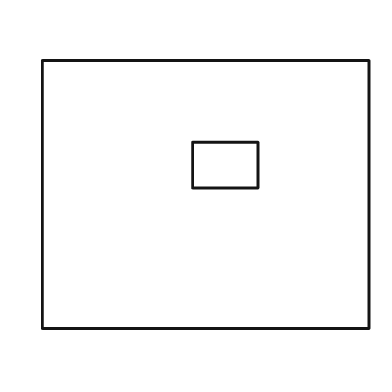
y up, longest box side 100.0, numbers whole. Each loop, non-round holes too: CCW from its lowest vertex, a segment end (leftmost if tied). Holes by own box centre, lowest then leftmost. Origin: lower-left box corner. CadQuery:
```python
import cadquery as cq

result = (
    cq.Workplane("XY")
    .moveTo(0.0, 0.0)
    .lineTo(100.0, 0.0)
    .lineTo(100.0, 82.0)
    .lineTo(0.0, 82.0)
    .close()
    .moveTo(46.0, 43.0)
    .lineTo(66.0, 43.0)
    .lineTo(66.0, 57.0)
    .lineTo(46.0, 57.0)
    .close()
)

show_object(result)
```